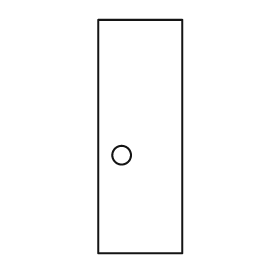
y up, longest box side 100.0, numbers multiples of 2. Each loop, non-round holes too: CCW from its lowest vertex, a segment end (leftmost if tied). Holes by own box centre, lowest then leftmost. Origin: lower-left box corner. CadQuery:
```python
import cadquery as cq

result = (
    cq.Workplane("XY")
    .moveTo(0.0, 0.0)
    .lineTo(36.0, 0.0)
    .lineTo(36.0, 100.0)
    .lineTo(0.0, 100.0)
    .close()
    .moveTo(10.0, 42.0)
    .circle(4.0)
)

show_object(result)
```